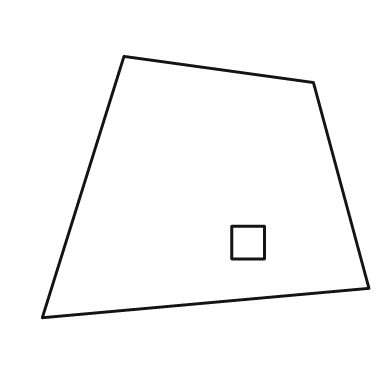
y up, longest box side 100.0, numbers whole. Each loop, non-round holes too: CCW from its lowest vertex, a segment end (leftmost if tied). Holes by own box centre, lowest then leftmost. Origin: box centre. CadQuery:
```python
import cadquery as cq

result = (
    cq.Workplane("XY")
    .moveTo(-50.0, -40.0)
    .lineTo(50.0, -31.0)
    .lineTo(33.0, 32.0)
    .lineTo(-25.0, 40.0)
    .close()
    .moveTo(8.0, -22.0)
    .lineTo(18.0, -22.0)
    .lineTo(18.0, -12.0)
    .lineTo(8.0, -12.0)
    .close()
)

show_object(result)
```